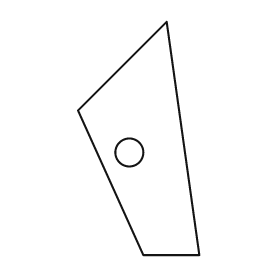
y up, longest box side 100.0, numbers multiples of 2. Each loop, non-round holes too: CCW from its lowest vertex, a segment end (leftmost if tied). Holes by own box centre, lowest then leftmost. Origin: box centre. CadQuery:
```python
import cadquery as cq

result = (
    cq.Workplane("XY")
    .moveTo(2.0, -50.0)
    .lineTo(26.0, -50.0)
    .lineTo(12.0, 50.0)
    .lineTo(-26.0, 12.0)
    .close()
    .moveTo(-4.0, -6.0)
    .circle(6.0)
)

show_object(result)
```